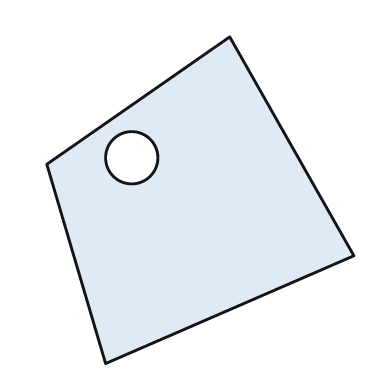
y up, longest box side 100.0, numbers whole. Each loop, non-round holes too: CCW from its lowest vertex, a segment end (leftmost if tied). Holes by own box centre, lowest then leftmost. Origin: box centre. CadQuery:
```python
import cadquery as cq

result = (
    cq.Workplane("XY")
    .moveTo(-29.0, -50.0)
    .lineTo(47.0, -17.0)
    .lineTo(9.0, 50.0)
    .lineTo(-47.0, 11.0)
    .close()
    .moveTo(-21.0, 13.0)
    .circle(8.0)
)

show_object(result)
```